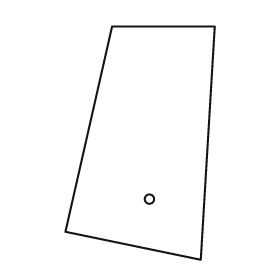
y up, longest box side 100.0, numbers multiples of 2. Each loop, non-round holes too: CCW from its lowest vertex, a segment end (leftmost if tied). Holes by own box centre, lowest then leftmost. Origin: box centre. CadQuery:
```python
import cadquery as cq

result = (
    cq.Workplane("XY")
    .moveTo(26.0, -50.0)
    .lineTo(32.0, 50.0)
    .lineTo(-12.0, 50.0)
    .lineTo(-32.0, -38.0)
    .close()
    .moveTo(4.0, -24.0)
    .circle(2.0)
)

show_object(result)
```